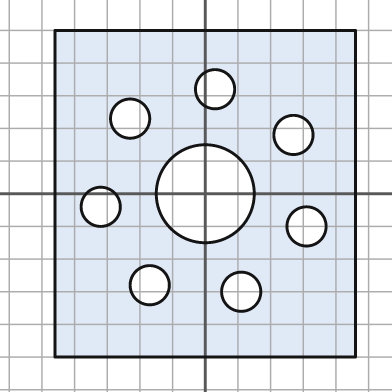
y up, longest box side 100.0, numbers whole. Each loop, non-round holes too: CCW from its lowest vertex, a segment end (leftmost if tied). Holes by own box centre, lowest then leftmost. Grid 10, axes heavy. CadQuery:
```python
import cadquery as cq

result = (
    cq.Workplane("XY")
    .moveTo(-46.0, -50.0)
    .lineTo(46.0, -50.0)
    .lineTo(46.0, 50.0)
    .lineTo(-46.0, 50.0)
    .close()
    .moveTo(11.0, -30.0)
    .circle(6.0)
    .moveTo(-17.0, -28.0)
    .circle(6.0)
    .moveTo(31.0, -10.0)
    .circle(6.0)
    .moveTo(-32.0, -4.0)
    .circle(6.0)
    .moveTo(0.0, 0.0)
    .circle(15.0)
    .moveTo(27.0, 18.0)
    .circle(6.0)
    .moveTo(-23.0, 23.0)
    .circle(6.0)
    .moveTo(3.0, 32.0)
    .circle(6.0)
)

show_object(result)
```